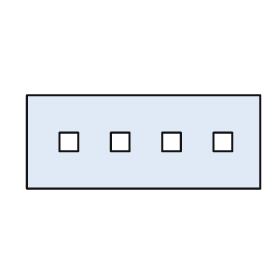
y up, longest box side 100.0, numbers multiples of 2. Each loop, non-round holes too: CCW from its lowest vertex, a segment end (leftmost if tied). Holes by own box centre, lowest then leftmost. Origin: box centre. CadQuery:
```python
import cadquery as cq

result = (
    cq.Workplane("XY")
    .moveTo(-50.0, -20.0)
    .lineTo(50.0, -20.0)
    .lineTo(50.0, 20.0)
    .lineTo(-50.0, 20.0)
    .close()
    .moveTo(-36.0, -4.0)
    .lineTo(-28.0, -4.0)
    .lineTo(-28.0, 4.0)
    .lineTo(-36.0, 4.0)
    .close()
    .moveTo(-14.0, -4.0)
    .lineTo(-6.0, -4.0)
    .lineTo(-6.0, 4.0)
    .lineTo(-14.0, 4.0)
    .close()
    .moveTo(8.0, -4.0)
    .lineTo(16.0, -4.0)
    .lineTo(16.0, 4.0)
    .lineTo(8.0, 4.0)
    .close()
    .moveTo(30.0, -4.0)
    .lineTo(38.0, -4.0)
    .lineTo(38.0, 4.0)
    .lineTo(30.0, 4.0)
    .close()
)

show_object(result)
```